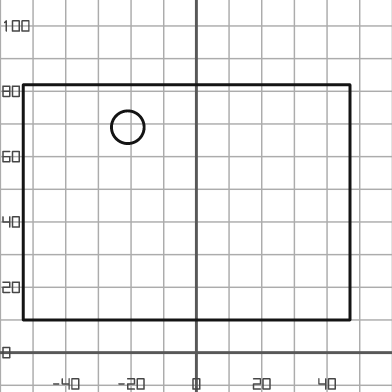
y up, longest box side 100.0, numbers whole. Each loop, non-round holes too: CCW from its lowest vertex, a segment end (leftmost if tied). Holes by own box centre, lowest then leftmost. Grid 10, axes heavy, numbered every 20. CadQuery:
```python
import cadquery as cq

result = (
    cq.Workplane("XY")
    .moveTo(-53.0, 10.0)
    .lineTo(47.0, 10.0)
    .lineTo(47.0, 82.0)
    .lineTo(-53.0, 82.0)
    .close()
    .moveTo(-21.0, 69.0)
    .circle(5.0)
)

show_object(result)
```